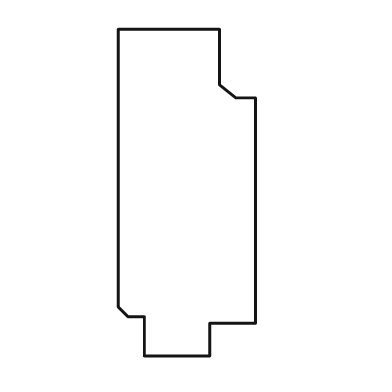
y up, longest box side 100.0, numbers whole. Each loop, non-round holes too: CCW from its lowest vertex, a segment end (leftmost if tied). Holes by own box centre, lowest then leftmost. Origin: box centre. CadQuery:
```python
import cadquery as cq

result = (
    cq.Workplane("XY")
    .moveTo(-13.0, -50.0)
    .lineTo(7.0, -50.0)
    .lineTo(7.0, -40.0)
    .lineTo(21.0, -40.0)
    .lineTo(21.0, 29.0)
    .lineTo(15.0, 29.0)
    .lineTo(10.0, 33.0)
    .lineTo(10.0, 50.0)
    .lineTo(-21.0, 50.0)
    .lineTo(-21.0, -35.0)
    .lineTo(-18.0, -38.0)
    .lineTo(-13.0, -38.0)
    .close()
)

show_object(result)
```